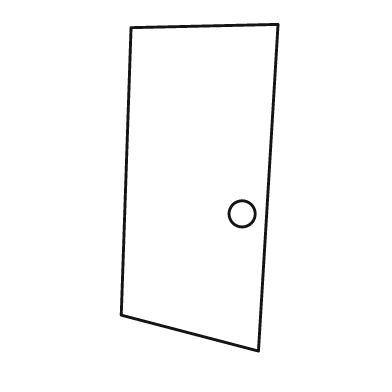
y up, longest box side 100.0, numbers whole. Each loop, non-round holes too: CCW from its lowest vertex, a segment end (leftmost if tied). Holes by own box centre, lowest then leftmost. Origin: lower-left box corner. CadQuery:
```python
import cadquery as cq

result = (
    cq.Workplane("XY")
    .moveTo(42.0, 0.0)
    .lineTo(48.0, 100.0)
    .lineTo(3.0, 99.0)
    .lineTo(0.0, 11.0)
    .close()
    .moveTo(37.0, 42.0)
    .circle(4.0)
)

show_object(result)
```